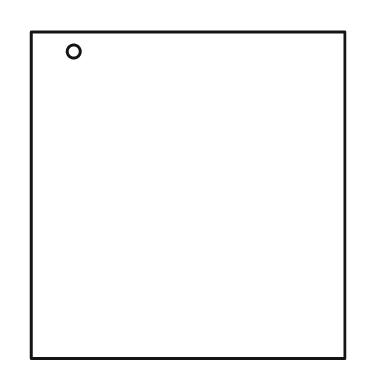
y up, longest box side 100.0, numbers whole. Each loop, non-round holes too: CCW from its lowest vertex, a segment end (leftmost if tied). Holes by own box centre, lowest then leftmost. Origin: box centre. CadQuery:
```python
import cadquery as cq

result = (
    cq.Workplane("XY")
    .moveTo(-48.0, -50.0)
    .lineTo(48.0, -50.0)
    .lineTo(48.0, 50.0)
    .lineTo(-48.0, 50.0)
    .close()
    .moveTo(-35.0, 44.0)
    .circle(2.0)
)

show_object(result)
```